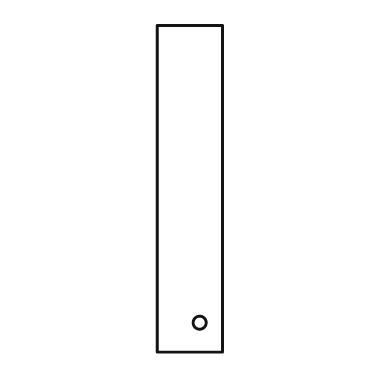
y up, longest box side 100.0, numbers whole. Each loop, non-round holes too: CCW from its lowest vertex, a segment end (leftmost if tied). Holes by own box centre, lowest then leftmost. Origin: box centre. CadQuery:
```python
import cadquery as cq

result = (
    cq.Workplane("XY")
    .moveTo(-10.0, -50.0)
    .lineTo(10.0, -50.0)
    .lineTo(10.0, 50.0)
    .lineTo(-10.0, 50.0)
    .close()
    .moveTo(3.0, -41.0)
    .circle(2.0)
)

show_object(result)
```